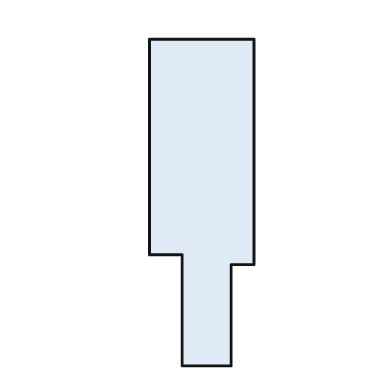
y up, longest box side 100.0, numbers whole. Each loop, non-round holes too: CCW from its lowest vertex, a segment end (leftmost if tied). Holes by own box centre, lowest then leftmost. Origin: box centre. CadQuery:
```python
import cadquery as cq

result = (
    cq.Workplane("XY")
    .moveTo(-6.0, -50.0)
    .lineTo(9.0, -50.0)
    .lineTo(9.0, -19.0)
    .lineTo(16.0, -19.0)
    .lineTo(16.0, 50.0)
    .lineTo(-16.0, 50.0)
    .lineTo(-16.0, -16.0)
    .lineTo(-6.0, -16.0)
    .close()
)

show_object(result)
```